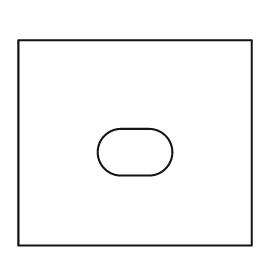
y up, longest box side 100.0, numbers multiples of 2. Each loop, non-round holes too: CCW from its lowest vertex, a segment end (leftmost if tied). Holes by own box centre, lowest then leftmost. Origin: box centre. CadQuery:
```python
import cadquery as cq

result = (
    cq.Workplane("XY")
    .moveTo(-50.0, -44.0)
    .lineTo(50.0, -44.0)
    .lineTo(50.0, 44.0)
    .lineTo(-50.0, 44.0)
    .close()
    .moveTo(-6.0, -14.0)
    .lineTo(6.0, -14.0)
    .threePointArc((16.0, -4.0), (6.0, 6.0))
    .lineTo(-6.0, 6.0)
    .threePointArc((-16.0, -4.0), (-6.0, -14.0))
    .close()
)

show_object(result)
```